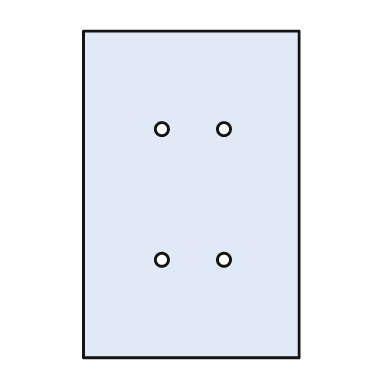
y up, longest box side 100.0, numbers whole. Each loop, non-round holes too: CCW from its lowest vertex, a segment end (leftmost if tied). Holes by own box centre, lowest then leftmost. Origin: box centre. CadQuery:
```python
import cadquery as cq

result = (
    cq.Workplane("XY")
    .moveTo(-33.0, -50.0)
    .lineTo(33.0, -50.0)
    .lineTo(33.0, 50.0)
    .lineTo(-33.0, 50.0)
    .close()
    .moveTo(-9.0, -20.0)
    .circle(2.0)
    .moveTo(10.0, -20.0)
    .circle(2.0)
    .moveTo(-9.0, 20.0)
    .circle(2.0)
    .moveTo(10.0, 20.0)
    .circle(2.0)
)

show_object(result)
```